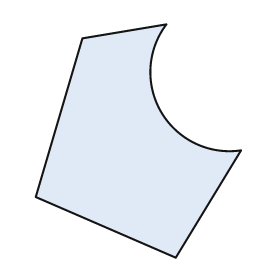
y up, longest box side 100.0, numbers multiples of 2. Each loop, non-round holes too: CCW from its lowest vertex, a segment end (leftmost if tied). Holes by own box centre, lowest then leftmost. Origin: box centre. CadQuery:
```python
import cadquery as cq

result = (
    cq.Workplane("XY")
    .moveTo(16.0, -50.0)
    .lineTo(44.0, -4.0)
    .threePointArc((10.0, 12.0), (12.0, 50.0))
    .lineTo(-24.0, 44.0)
    .lineTo(-44.0, -24.0)
    .close()
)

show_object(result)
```